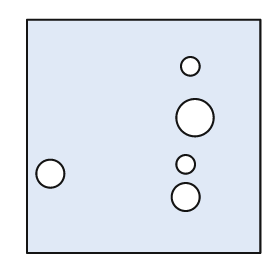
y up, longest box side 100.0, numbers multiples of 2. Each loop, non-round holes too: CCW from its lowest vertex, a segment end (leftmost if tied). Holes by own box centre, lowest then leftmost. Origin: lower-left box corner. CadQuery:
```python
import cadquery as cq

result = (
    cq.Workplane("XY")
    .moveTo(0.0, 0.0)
    .lineTo(100.0, 0.0)
    .lineTo(100.0, 100.0)
    .lineTo(0.0, 100.0)
    .close()
    .moveTo(68.0, 24.0)
    .circle(6.0)
    .moveTo(10.0, 34.0)
    .circle(6.0)
    .moveTo(68.0, 38.0)
    .circle(4.0)
    .moveTo(72.0, 58.0)
    .circle(8.0)
    .moveTo(70.0, 80.0)
    .circle(4.0)
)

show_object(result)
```